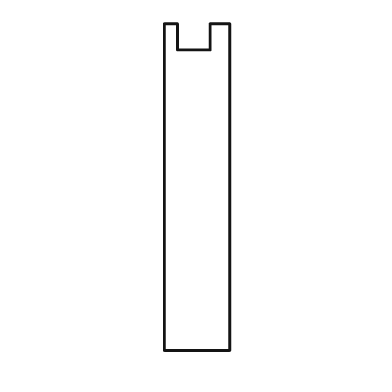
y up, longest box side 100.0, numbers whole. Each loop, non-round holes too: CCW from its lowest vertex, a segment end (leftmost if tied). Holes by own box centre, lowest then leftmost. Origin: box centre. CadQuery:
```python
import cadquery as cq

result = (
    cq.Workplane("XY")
    .moveTo(-10.0, -50.0)
    .lineTo(10.0, -50.0)
    .lineTo(10.0, 50.0)
    .lineTo(4.0, 50.0)
    .lineTo(4.0, 42.0)
    .lineTo(-6.0, 42.0)
    .lineTo(-6.0, 50.0)
    .lineTo(-10.0, 50.0)
    .close()
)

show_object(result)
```